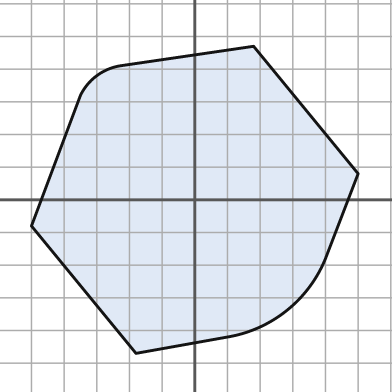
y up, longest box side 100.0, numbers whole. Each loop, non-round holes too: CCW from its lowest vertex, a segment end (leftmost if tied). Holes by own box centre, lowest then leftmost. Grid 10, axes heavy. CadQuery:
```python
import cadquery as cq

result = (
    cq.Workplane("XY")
    .moveTo(-18.0, -47.0)
    .lineTo(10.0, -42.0)
    .threePointArc((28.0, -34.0), (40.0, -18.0))
    .lineTo(50.0, 8.0)
    .lineTo(18.0, 47.0)
    .lineTo(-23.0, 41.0)
    .threePointArc((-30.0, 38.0), (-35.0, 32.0))
    .lineTo(-50.0, -8.0)
    .close()
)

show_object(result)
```